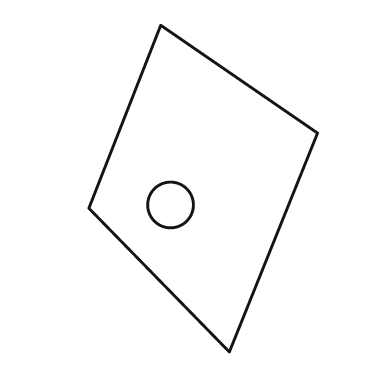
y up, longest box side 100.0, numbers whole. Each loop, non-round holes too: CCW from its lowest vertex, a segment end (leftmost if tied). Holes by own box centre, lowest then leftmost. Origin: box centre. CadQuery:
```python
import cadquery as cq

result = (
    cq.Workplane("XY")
    .moveTo(8.0, -50.0)
    .lineTo(35.0, 17.0)
    .lineTo(-13.0, 50.0)
    .lineTo(-35.0, -6.0)
    .close()
    .moveTo(-10.0, -5.0)
    .circle(7.0)
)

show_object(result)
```